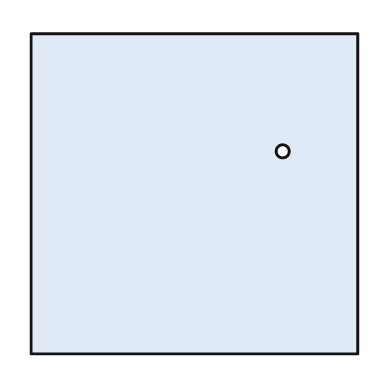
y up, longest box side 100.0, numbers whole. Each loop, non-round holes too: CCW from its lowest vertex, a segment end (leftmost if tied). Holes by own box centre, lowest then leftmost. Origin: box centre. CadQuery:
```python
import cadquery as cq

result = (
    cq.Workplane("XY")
    .moveTo(-50.0, -49.0)
    .lineTo(50.0, -49.0)
    .lineTo(50.0, 49.0)
    .lineTo(-50.0, 49.0)
    .close()
    .moveTo(27.0, 13.0)
    .circle(2.0)
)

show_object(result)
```